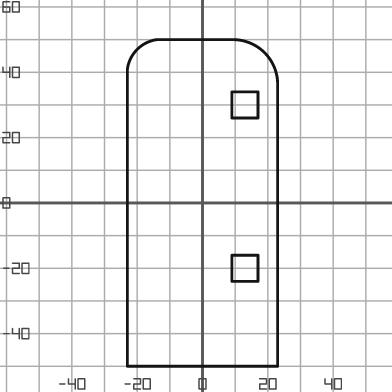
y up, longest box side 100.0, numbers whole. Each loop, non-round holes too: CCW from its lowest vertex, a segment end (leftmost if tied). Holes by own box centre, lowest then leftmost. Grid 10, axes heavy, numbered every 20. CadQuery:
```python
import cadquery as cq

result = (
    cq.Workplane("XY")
    .moveTo(-23.0, -50.0)
    .lineTo(23.0, -50.0)
    .lineTo(23.0, 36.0)
    .threePointArc((19.0, 46.0), (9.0, 50.0))
    .lineTo(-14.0, 50.0)
    .threePointArc((-20.0, 47.0), (-23.0, 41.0))
    .close()
    .moveTo(9.0, -24.0)
    .lineTo(17.0, -24.0)
    .lineTo(17.0, -16.0)
    .lineTo(9.0, -16.0)
    .close()
    .moveTo(9.0, 26.0)
    .lineTo(17.0, 26.0)
    .lineTo(17.0, 34.0)
    .lineTo(9.0, 34.0)
    .close()
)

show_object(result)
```